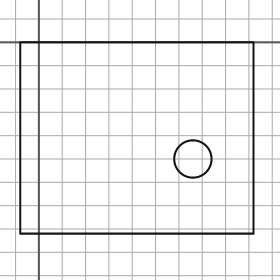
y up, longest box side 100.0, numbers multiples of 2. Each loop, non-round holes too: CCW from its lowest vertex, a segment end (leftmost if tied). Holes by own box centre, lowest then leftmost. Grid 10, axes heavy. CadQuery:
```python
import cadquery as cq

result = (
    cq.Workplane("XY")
    .moveTo(-8.0, -82.0)
    .lineTo(92.0, -82.0)
    .lineTo(92.0, 0.0)
    .lineTo(-8.0, 0.0)
    .close()
    .moveTo(66.0, -50.0)
    .circle(8.0)
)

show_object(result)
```